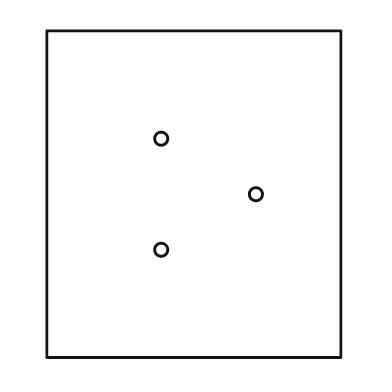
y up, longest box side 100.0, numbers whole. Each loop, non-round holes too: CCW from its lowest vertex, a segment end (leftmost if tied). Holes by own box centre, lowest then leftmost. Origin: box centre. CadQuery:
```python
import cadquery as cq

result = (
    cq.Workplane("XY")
    .moveTo(-45.0, -50.0)
    .lineTo(45.0, -50.0)
    .lineTo(45.0, 50.0)
    .lineTo(-45.0, 50.0)
    .close()
    .moveTo(-10.0, -17.0)
    .circle(2.0)
    .moveTo(19.0, 0.0)
    .circle(2.0)
    .moveTo(-10.0, 17.0)
    .circle(2.0)
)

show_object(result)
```